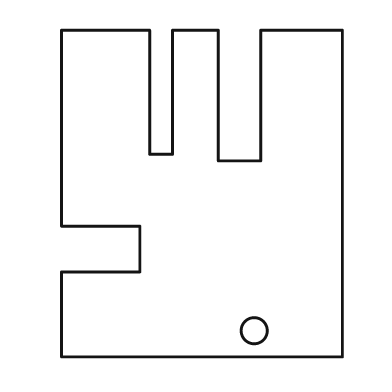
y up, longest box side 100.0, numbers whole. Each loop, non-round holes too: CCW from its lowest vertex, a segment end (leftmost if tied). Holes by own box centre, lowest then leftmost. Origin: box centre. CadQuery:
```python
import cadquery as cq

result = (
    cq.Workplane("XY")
    .moveTo(-43.0, -50.0)
    .lineTo(43.0, -50.0)
    .lineTo(43.0, 50.0)
    .lineTo(18.0, 50.0)
    .lineTo(18.0, 10.0)
    .lineTo(5.0, 10.0)
    .lineTo(5.0, 50.0)
    .lineTo(-9.0, 50.0)
    .lineTo(-9.0, 12.0)
    .lineTo(-16.0, 12.0)
    .lineTo(-16.0, 50.0)
    .lineTo(-43.0, 50.0)
    .lineTo(-43.0, -10.0)
    .lineTo(-19.0, -10.0)
    .lineTo(-19.0, -24.0)
    .lineTo(-43.0, -24.0)
    .close()
    .moveTo(16.0, -42.0)
    .circle(4.0)
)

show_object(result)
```